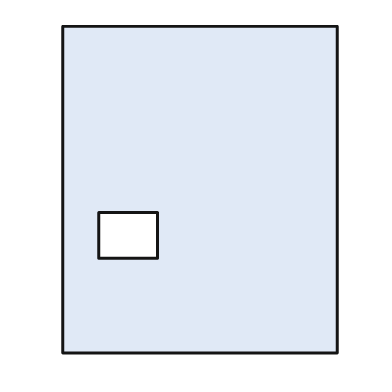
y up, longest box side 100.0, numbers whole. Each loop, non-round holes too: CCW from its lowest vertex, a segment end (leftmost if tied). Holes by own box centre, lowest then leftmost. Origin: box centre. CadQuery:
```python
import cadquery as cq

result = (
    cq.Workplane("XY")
    .moveTo(-42.0, -50.0)
    .lineTo(42.0, -50.0)
    .lineTo(42.0, 50.0)
    .lineTo(-42.0, 50.0)
    .close()
    .moveTo(-31.0, -21.0)
    .lineTo(-13.0, -21.0)
    .lineTo(-13.0, -7.0)
    .lineTo(-31.0, -7.0)
    .close()
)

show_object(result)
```